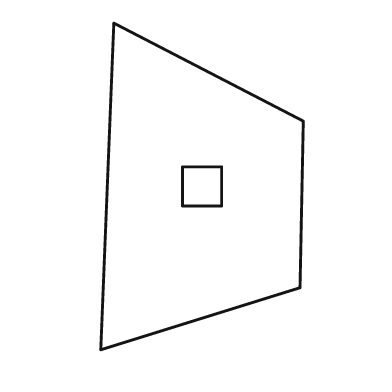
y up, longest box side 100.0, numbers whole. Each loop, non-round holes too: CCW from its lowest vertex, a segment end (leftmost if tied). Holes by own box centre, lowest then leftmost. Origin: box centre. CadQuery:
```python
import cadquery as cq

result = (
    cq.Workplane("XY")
    .moveTo(-31.0, -50.0)
    .lineTo(30.0, -31.0)
    .lineTo(31.0, 20.0)
    .lineTo(-27.0, 50.0)
    .close()
    .moveTo(-6.0, -6.0)
    .lineTo(6.0, -6.0)
    .lineTo(6.0, 6.0)
    .lineTo(-6.0, 6.0)
    .close()
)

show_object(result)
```